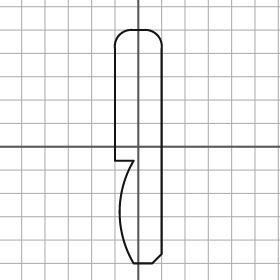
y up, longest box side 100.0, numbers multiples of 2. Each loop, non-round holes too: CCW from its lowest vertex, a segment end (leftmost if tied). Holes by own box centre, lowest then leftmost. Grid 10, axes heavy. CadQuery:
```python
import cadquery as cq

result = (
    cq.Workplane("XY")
    .moveTo(-2.0, -50.0)
    .lineTo(6.0, -50.0)
    .lineTo(10.0, -46.0)
    .lineTo(10.0, 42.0)
    .threePointArc((8.0, 48.0), (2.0, 50.0))
    .lineTo(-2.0, 50.0)
    .threePointArc((-8.0, 48.0), (-10.0, 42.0))
    .lineTo(-10.0, -6.0)
    .lineTo(-2.0, -6.0)
    .threePointArc((-8.0, -28.0), (-2.0, -50.0))
    .close()
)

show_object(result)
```